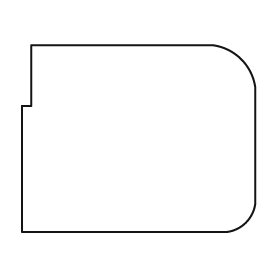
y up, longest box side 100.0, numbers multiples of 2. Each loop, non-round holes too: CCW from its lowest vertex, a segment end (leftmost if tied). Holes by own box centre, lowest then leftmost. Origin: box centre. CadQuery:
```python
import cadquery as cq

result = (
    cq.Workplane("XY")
    .moveTo(-50.0, -40.0)
    .lineTo(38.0, -40.0)
    .threePointArc((46.0, -36.0), (50.0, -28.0))
    .lineTo(50.0, 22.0)
    .threePointArc((44.0, 34.0), (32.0, 40.0))
    .lineTo(-46.0, 40.0)
    .lineTo(-46.0, 14.0)
    .lineTo(-50.0, 14.0)
    .close()
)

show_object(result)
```